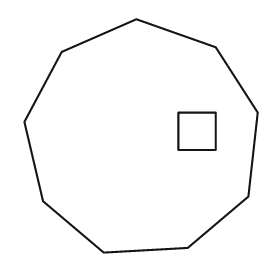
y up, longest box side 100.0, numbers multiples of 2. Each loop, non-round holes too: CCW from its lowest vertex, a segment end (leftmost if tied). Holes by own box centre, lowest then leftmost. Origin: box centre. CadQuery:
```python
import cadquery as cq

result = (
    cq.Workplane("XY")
    .moveTo(-16.0, -50.0)
    .lineTo(20.0, -48.0)
    .lineTo(46.0, -26.0)
    .lineTo(50.0, 10.0)
    .lineTo(32.0, 38.0)
    .lineTo(-2.0, 50.0)
    .lineTo(-34.0, 36.0)
    .lineTo(-50.0, 6.0)
    .lineTo(-42.0, -28.0)
    .close()
    .moveTo(16.0, -6.0)
    .lineTo(32.0, -6.0)
    .lineTo(32.0, 10.0)
    .lineTo(16.0, 10.0)
    .close()
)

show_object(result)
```